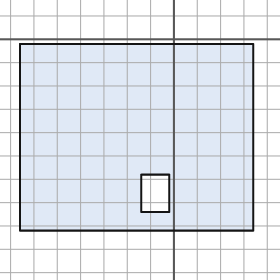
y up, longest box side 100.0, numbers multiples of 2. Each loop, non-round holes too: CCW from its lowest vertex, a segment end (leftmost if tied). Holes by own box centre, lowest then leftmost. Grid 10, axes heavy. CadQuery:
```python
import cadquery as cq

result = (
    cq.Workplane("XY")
    .moveTo(-66.0, -82.0)
    .lineTo(34.0, -82.0)
    .lineTo(34.0, -2.0)
    .lineTo(-66.0, -2.0)
    .close()
    .moveTo(-14.0, -74.0)
    .lineTo(-2.0, -74.0)
    .lineTo(-2.0, -58.0)
    .lineTo(-14.0, -58.0)
    .close()
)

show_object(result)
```